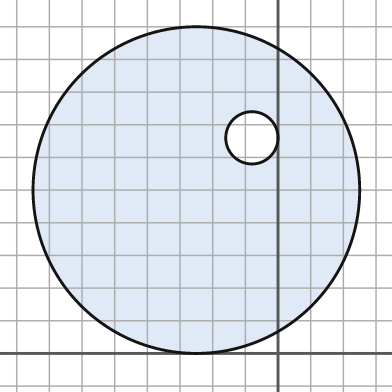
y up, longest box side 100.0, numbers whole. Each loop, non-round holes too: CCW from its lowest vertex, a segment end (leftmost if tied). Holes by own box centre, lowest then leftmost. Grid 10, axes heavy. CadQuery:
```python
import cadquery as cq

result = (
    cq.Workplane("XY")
    .moveTo(-25.0, 50.0)
    .circle(50.0)
    .moveTo(-8.0, 66.0)
    .circle(8.0)
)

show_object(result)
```